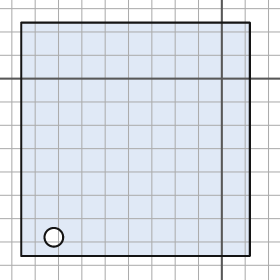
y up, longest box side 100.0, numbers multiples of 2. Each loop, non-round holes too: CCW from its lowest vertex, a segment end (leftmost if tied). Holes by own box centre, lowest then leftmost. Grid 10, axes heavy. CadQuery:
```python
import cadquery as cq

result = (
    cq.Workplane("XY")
    .moveTo(-86.0, -76.0)
    .lineTo(12.0, -76.0)
    .lineTo(12.0, 24.0)
    .lineTo(-86.0, 24.0)
    .close()
    .moveTo(-72.0, -68.0)
    .circle(4.0)
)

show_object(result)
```